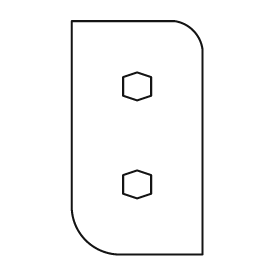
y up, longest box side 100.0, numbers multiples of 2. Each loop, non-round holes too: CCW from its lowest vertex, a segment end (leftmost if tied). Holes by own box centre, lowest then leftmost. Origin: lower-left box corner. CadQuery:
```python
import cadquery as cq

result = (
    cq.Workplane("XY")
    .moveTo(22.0, 0.0)
    .lineTo(56.0, 0.0)
    .lineTo(56.0, 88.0)
    .threePointArc((52.0, 96.0), (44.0, 100.0))
    .lineTo(0.0, 100.0)
    .lineTo(0.0, 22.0)
    .threePointArc((6.0, 6.0), (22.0, 0.0))
    .close()
    .moveTo(28.0, 24.0)
    .lineTo(34.0, 26.0)
    .lineTo(34.0, 34.0)
    .lineTo(28.0, 36.0)
    .lineTo(22.0, 34.0)
    .lineTo(22.0, 26.0)
    .close()
    .moveTo(28.0, 66.0)
    .lineTo(34.0, 68.0)
    .lineTo(34.0, 76.0)
    .lineTo(28.0, 78.0)
    .lineTo(22.0, 76.0)
    .lineTo(22.0, 68.0)
    .close()
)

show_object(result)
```